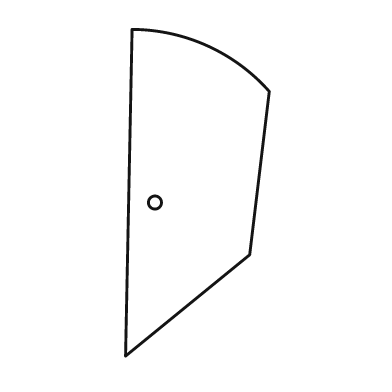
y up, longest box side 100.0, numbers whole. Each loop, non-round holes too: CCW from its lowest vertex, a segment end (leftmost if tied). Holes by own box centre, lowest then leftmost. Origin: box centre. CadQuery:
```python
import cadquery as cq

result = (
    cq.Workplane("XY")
    .moveTo(-22.0, -50.0)
    .lineTo(16.0, -19.0)
    .lineTo(22.0, 31.0)
    .threePointArc((3.0, 45.0), (-20.0, 50.0))
    .close()
    .moveTo(-13.0, -3.0)
    .circle(2.0)
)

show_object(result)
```